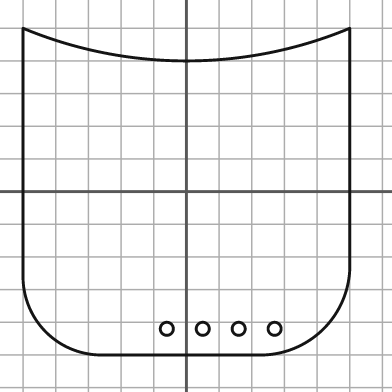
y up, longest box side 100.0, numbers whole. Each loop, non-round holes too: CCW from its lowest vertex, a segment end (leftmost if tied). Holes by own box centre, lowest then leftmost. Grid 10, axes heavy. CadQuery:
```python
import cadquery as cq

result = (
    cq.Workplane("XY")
    .moveTo(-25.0, -50.0)
    .lineTo(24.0, -50.0)
    .threePointArc((42.0, -42.0), (50.0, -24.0))
    .lineTo(50.0, 50.0)
    .threePointArc((0.0, 40.0), (-50.0, 50.0))
    .lineTo(-50.0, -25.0)
    .threePointArc((-43.0, -43.0), (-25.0, -50.0))
    .close()
    .moveTo(-6.0, -42.0)
    .circle(2.0)
    .moveTo(5.0, -42.0)
    .circle(2.0)
    .moveTo(16.0, -42.0)
    .circle(2.0)
    .moveTo(27.0, -42.0)
    .circle(2.0)
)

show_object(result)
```